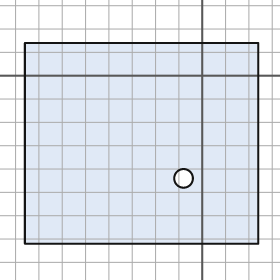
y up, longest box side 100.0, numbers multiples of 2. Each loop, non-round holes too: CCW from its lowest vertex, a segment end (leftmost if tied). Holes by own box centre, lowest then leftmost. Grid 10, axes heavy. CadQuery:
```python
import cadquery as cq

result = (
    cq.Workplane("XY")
    .moveTo(-76.0, -72.0)
    .lineTo(24.0, -72.0)
    .lineTo(24.0, 14.0)
    .lineTo(-76.0, 14.0)
    .close()
    .moveTo(-8.0, -44.0)
    .circle(4.0)
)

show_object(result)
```